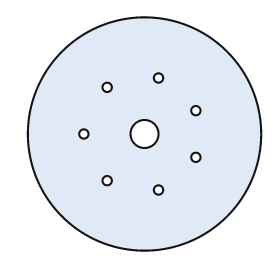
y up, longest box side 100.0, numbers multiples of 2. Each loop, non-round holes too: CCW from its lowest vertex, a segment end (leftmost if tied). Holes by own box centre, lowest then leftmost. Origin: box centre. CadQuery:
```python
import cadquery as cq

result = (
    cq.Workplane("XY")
    .moveTo(0.0, 0.0)
    .circle(50.0)
    .moveTo(6.0, -24.0)
    .circle(2.0)
    .moveTo(-16.0, -20.0)
    .circle(2.0)
    .moveTo(22.0, -10.0)
    .circle(2.0)
    .moveTo(-26.0, 0.0)
    .circle(2.0)
    .moveTo(0.0, 0.0)
    .circle(6.0)
    .moveTo(22.0, 10.0)
    .circle(2.0)
    .moveTo(-16.0, 20.0)
    .circle(2.0)
    .moveTo(6.0, 24.0)
    .circle(2.0)
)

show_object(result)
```